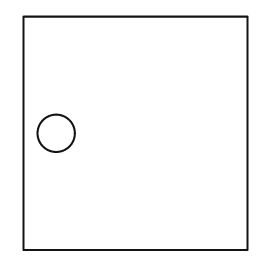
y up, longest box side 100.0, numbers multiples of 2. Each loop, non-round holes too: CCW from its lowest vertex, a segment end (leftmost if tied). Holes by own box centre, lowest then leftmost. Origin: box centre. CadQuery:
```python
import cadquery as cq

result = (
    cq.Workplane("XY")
    .moveTo(-48.0, -50.0)
    .lineTo(48.0, -50.0)
    .lineTo(48.0, 50.0)
    .lineTo(-48.0, 50.0)
    .close()
    .moveTo(-34.0, 0.0)
    .circle(8.0)
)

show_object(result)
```